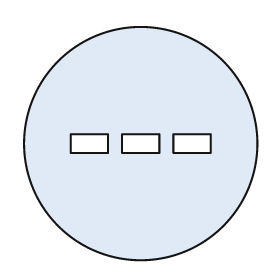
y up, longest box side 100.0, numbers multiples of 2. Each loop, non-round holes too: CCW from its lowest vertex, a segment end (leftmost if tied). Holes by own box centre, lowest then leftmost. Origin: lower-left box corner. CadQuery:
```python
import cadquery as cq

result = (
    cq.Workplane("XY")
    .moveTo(50.0, 50.0)
    .circle(50.0)
    .moveTo(20.0, 46.0)
    .lineTo(36.0, 46.0)
    .lineTo(36.0, 54.0)
    .lineTo(20.0, 54.0)
    .close()
    .moveTo(42.0, 46.0)
    .lineTo(58.0, 46.0)
    .lineTo(58.0, 54.0)
    .lineTo(42.0, 54.0)
    .close()
    .moveTo(64.0, 46.0)
    .lineTo(80.0, 46.0)
    .lineTo(80.0, 54.0)
    .lineTo(64.0, 54.0)
    .close()
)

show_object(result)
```